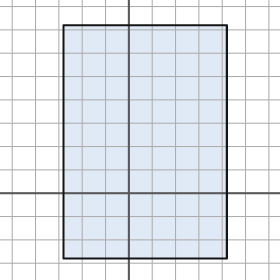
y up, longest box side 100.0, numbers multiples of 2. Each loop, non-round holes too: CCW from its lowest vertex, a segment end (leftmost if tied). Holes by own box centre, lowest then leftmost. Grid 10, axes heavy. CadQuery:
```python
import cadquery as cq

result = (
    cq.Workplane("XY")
    .moveTo(-28.0, -28.0)
    .lineTo(42.0, -28.0)
    .lineTo(42.0, 72.0)
    .lineTo(-28.0, 72.0)
    .close()
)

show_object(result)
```